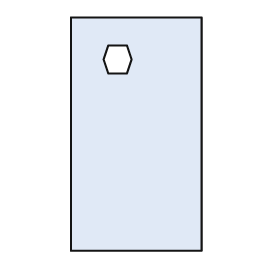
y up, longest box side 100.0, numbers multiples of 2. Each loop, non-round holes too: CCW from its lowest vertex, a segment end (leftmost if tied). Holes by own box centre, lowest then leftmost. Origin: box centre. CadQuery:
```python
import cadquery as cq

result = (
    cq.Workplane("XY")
    .moveTo(-28.0, -50.0)
    .lineTo(28.0, -50.0)
    .lineTo(28.0, 50.0)
    .lineTo(-28.0, 50.0)
    .close()
    .moveTo(-12.0, 26.0)
    .lineTo(-4.0, 26.0)
    .lineTo(-2.0, 32.0)
    .lineTo(-4.0, 38.0)
    .lineTo(-12.0, 38.0)
    .lineTo(-14.0, 32.0)
    .close()
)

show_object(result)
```